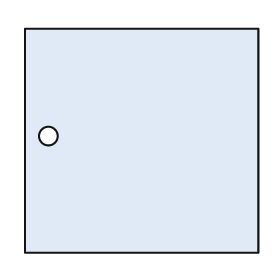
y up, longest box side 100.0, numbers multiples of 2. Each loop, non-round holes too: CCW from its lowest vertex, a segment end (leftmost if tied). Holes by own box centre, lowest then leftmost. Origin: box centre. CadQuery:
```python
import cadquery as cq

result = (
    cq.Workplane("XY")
    .moveTo(-50.0, -48.0)
    .lineTo(50.0, -48.0)
    .lineTo(50.0, 48.0)
    .lineTo(-50.0, 48.0)
    .close()
    .moveTo(-40.0, 2.0)
    .circle(4.0)
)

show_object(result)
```